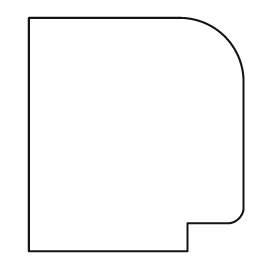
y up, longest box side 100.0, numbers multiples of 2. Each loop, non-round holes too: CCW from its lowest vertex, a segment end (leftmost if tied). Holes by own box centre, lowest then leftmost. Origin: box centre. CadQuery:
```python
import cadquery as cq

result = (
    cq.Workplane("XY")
    .moveTo(-46.0, -50.0)
    .lineTo(22.0, -50.0)
    .lineTo(22.0, -38.0)
    .lineTo(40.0, -38.0)
    .threePointArc((44.0, -36.0), (46.0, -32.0))
    .lineTo(46.0, 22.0)
    .threePointArc((38.0, 42.0), (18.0, 50.0))
    .lineTo(-46.0, 50.0)
    .close()
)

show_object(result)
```